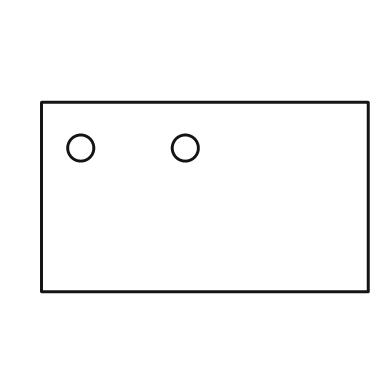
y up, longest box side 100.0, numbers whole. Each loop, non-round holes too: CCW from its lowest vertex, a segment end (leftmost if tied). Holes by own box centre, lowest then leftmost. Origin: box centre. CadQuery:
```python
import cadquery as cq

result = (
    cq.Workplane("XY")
    .moveTo(-50.0, -29.0)
    .lineTo(50.0, -29.0)
    .lineTo(50.0, 29.0)
    .lineTo(-50.0, 29.0)
    .close()
    .moveTo(-38.0, 15.0)
    .circle(4.0)
    .moveTo(-6.0, 15.0)
    .circle(4.0)
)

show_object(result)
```